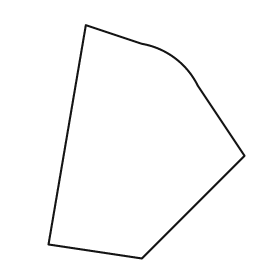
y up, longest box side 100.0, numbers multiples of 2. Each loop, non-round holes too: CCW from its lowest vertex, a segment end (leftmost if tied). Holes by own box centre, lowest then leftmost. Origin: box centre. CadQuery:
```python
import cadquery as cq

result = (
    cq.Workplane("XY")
    .moveTo(-2.0, -50.0)
    .lineTo(42.0, -6.0)
    .lineTo(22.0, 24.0)
    .threePointArc((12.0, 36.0), (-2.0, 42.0))
    .lineTo(-26.0, 50.0)
    .lineTo(-42.0, -44.0)
    .close()
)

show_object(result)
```